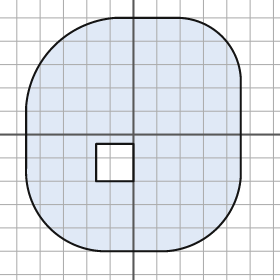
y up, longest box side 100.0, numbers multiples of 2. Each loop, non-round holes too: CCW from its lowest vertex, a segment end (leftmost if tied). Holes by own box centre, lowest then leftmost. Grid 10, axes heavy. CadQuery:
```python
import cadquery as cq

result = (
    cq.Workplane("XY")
    .moveTo(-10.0, -50.0)
    .lineTo(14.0, -50.0)
    .threePointArc((36.0, -40.0), (46.0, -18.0))
    .lineTo(46.0, 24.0)
    .threePointArc((38.0, 42.0), (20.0, 50.0))
    .lineTo(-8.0, 50.0)
    .threePointArc((-34.0, 38.0), (-46.0, 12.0))
    .lineTo(-46.0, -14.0)
    .threePointArc((-36.0, -40.0), (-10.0, -50.0))
    .close()
    .moveTo(-16.0, -20.0)
    .lineTo(0.0, -20.0)
    .lineTo(0.0, -4.0)
    .lineTo(-16.0, -4.0)
    .close()
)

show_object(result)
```